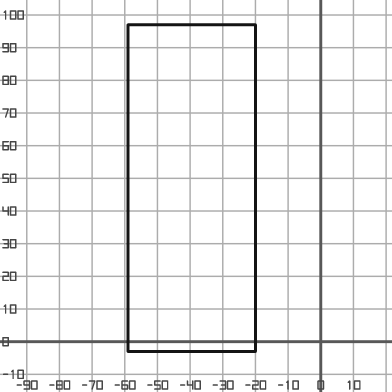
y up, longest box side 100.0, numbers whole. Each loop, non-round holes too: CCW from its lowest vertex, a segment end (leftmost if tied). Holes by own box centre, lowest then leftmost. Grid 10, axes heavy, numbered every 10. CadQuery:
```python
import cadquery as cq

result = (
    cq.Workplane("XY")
    .moveTo(-59.0, -3.0)
    .lineTo(-20.0, -3.0)
    .lineTo(-20.0, 97.0)
    .lineTo(-59.0, 97.0)
    .close()
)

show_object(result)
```